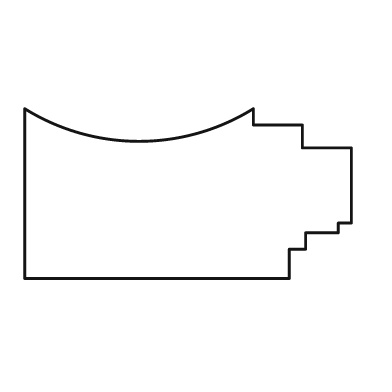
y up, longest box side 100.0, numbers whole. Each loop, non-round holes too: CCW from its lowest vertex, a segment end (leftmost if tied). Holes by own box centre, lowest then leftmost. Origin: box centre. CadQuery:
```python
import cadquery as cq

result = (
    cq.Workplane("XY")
    .moveTo(-50.0, -26.0)
    .lineTo(31.0, -26.0)
    .lineTo(31.0, -17.0)
    .lineTo(36.0, -17.0)
    .lineTo(36.0, -12.0)
    .lineTo(46.0, -12.0)
    .lineTo(46.0, -9.0)
    .lineTo(50.0, -9.0)
    .lineTo(50.0, 14.0)
    .lineTo(35.0, 14.0)
    .lineTo(35.0, 21.0)
    .lineTo(20.0, 21.0)
    .lineTo(20.0, 26.0)
    .threePointArc((-15.0, 16.0), (-50.0, 26.0))
    .close()
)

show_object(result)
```